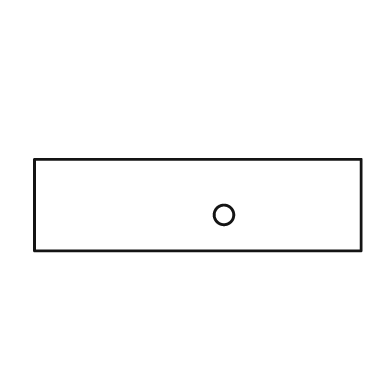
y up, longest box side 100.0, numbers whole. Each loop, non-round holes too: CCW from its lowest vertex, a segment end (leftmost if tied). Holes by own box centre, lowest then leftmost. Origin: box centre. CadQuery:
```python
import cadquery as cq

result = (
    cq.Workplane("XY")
    .moveTo(-50.0, -14.0)
    .lineTo(50.0, -14.0)
    .lineTo(50.0, 14.0)
    .lineTo(-50.0, 14.0)
    .close()
    .moveTo(8.0, -3.0)
    .circle(3.0)
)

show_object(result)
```